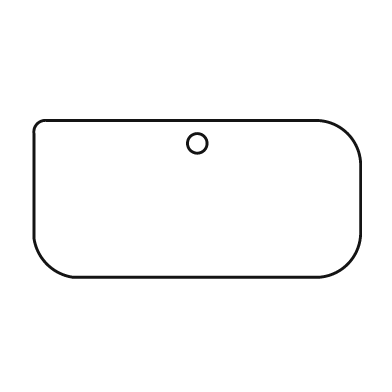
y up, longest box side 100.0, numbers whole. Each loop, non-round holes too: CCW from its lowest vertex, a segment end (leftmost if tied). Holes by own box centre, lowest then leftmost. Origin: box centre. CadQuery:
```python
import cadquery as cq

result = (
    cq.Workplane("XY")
    .moveTo(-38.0, -24.0)
    .lineTo(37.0, -24.0)
    .threePointArc((46.0, -20.0), (50.0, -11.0))
    .lineTo(50.0, 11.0)
    .threePointArc((46.0, 20.0), (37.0, 24.0))
    .lineTo(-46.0, 24.0)
    .threePointArc((-49.0, 23.0), (-50.0, 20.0))
    .lineTo(-50.0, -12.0)
    .threePointArc((-46.0, -20.0), (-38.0, -24.0))
    .close()
    .moveTo(0.0, 17.0)
    .circle(3.0)
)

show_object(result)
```